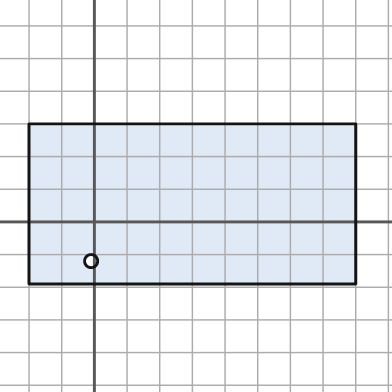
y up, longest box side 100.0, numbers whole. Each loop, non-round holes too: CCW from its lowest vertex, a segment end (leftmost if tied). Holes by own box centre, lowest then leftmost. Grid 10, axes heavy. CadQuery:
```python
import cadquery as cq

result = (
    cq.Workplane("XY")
    .moveTo(-20.0, -19.0)
    .lineTo(80.0, -19.0)
    .lineTo(80.0, 30.0)
    .lineTo(-20.0, 30.0)
    .close()
    .moveTo(-1.0, -12.0)
    .circle(2.0)
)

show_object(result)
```